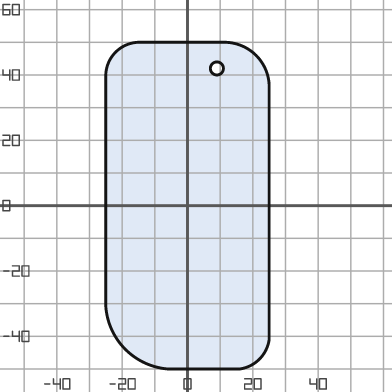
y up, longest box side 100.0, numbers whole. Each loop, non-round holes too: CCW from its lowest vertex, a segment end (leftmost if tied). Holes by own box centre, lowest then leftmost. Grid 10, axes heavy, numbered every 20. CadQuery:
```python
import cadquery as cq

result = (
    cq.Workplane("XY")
    .moveTo(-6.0, -50.0)
    .lineTo(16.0, -50.0)
    .threePointArc((22.0, -47.0), (25.0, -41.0))
    .lineTo(25.0, 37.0)
    .threePointArc((21.0, 46.0), (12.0, 50.0))
    .lineTo(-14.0, 50.0)
    .threePointArc((-22.0, 47.0), (-25.0, 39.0))
    .lineTo(-25.0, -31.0)
    .threePointArc((-19.0, -44.0), (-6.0, -50.0))
    .close()
    .moveTo(9.0, 42.0)
    .circle(2.0)
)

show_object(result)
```